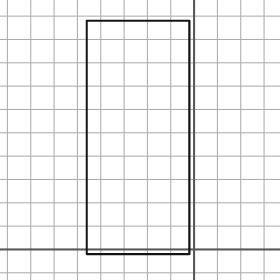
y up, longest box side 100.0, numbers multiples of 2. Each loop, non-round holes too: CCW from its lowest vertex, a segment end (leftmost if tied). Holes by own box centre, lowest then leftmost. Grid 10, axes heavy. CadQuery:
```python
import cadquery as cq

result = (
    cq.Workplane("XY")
    .moveTo(-46.0, -2.0)
    .lineTo(-2.0, -2.0)
    .lineTo(-2.0, 98.0)
    .lineTo(-46.0, 98.0)
    .close()
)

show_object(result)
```